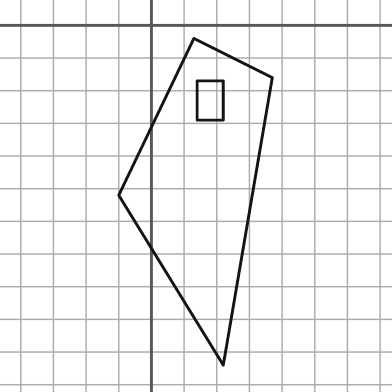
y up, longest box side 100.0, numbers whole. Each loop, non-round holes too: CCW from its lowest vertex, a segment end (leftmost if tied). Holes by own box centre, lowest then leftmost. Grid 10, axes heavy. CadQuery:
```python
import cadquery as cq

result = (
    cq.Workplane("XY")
    .moveTo(22.0, -104.0)
    .lineTo(37.0, -16.0)
    .lineTo(13.0, -4.0)
    .lineTo(-10.0, -52.0)
    .close()
    .moveTo(14.0, -29.0)
    .lineTo(22.0, -29.0)
    .lineTo(22.0, -17.0)
    .lineTo(14.0, -17.0)
    .close()
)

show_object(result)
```